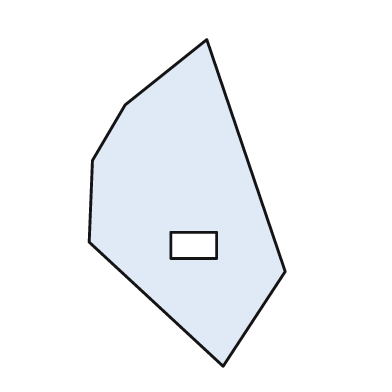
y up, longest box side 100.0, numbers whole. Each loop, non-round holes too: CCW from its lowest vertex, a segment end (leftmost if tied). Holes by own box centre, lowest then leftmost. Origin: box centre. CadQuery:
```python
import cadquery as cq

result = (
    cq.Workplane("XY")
    .moveTo(11.0, -50.0)
    .lineTo(30.0, -21.0)
    .lineTo(6.0, 50.0)
    .lineTo(-19.0, 30.0)
    .lineTo(-29.0, 13.0)
    .lineTo(-30.0, -12.0)
    .close()
    .moveTo(-5.0, -17.0)
    .lineTo(9.0, -17.0)
    .lineTo(9.0, -9.0)
    .lineTo(-5.0, -9.0)
    .close()
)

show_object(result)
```